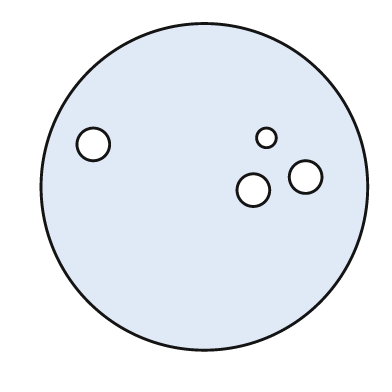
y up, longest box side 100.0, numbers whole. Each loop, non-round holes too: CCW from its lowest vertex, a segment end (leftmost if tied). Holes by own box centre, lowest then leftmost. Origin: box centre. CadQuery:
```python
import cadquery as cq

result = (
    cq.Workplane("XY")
    .moveTo(0.0, 0.0)
    .circle(50.0)
    .moveTo(15.0, -1.0)
    .circle(5.0)
    .moveTo(31.0, 3.0)
    .circle(5.0)
    .moveTo(-34.0, 13.0)
    .circle(5.0)
    .moveTo(19.0, 15.0)
    .circle(3.0)
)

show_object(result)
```